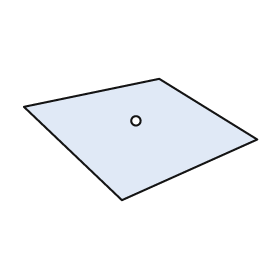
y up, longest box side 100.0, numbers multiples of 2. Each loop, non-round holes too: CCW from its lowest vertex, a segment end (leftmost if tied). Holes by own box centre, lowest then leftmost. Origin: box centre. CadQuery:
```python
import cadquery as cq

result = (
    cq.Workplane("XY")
    .moveTo(-8.0, -26.0)
    .lineTo(50.0, 0.0)
    .lineTo(8.0, 26.0)
    .lineTo(-50.0, 14.0)
    .close()
    .moveTo(-2.0, 8.0)
    .circle(2.0)
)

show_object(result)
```